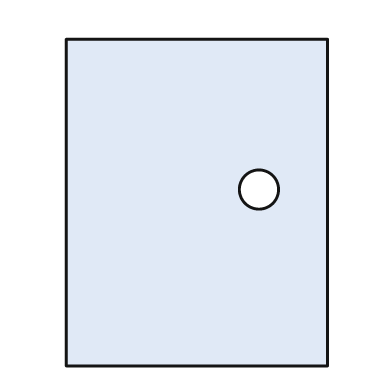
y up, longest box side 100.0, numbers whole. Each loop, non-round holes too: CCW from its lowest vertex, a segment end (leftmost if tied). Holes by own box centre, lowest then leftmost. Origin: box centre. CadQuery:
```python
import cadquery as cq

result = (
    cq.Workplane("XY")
    .moveTo(-40.0, -50.0)
    .lineTo(40.0, -50.0)
    .lineTo(40.0, 50.0)
    .lineTo(-40.0, 50.0)
    .close()
    .moveTo(19.0, 4.0)
    .circle(6.0)
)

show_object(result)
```